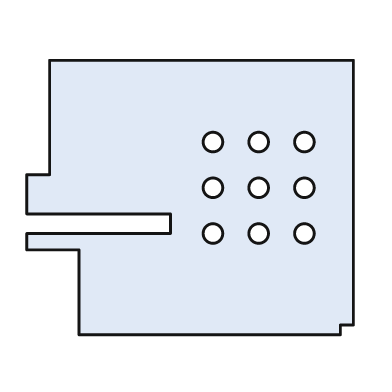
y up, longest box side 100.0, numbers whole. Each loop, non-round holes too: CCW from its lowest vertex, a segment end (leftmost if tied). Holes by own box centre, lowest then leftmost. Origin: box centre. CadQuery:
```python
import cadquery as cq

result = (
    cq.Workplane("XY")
    .moveTo(-34.0, -42.0)
    .lineTo(46.0, -42.0)
    .lineTo(46.0, -39.0)
    .lineTo(50.0, -39.0)
    .lineTo(50.0, 42.0)
    .lineTo(-43.0, 42.0)
    .lineTo(-43.0, 7.0)
    .lineTo(-50.0, 7.0)
    .lineTo(-50.0, -5.0)
    .lineTo(-6.0, -5.0)
    .lineTo(-6.0, -11.0)
    .lineTo(-50.0, -11.0)
    .lineTo(-50.0, -16.0)
    .lineTo(-34.0, -16.0)
    .close()
    .moveTo(7.0, -11.0)
    .circle(3.0)
    .moveTo(21.0, -11.0)
    .circle(3.0)
    .moveTo(35.0, -11.0)
    .circle(3.0)
    .moveTo(7.0, 3.0)
    .circle(3.0)
    .moveTo(21.0, 3.0)
    .circle(3.0)
    .moveTo(35.0, 3.0)
    .circle(3.0)
    .moveTo(7.0, 17.0)
    .circle(3.0)
    .moveTo(21.0, 17.0)
    .circle(3.0)
    .moveTo(35.0, 17.0)
    .circle(3.0)
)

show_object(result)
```